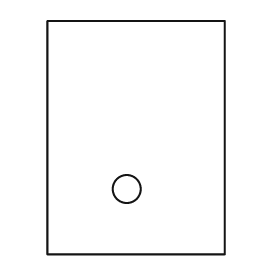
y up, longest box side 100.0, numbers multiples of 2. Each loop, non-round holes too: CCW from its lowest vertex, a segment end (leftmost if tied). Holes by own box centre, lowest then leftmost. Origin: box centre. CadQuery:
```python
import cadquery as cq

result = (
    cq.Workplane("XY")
    .moveTo(-38.0, -50.0)
    .lineTo(38.0, -50.0)
    .lineTo(38.0, 50.0)
    .lineTo(-38.0, 50.0)
    .close()
    .moveTo(-4.0, -22.0)
    .circle(6.0)
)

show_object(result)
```